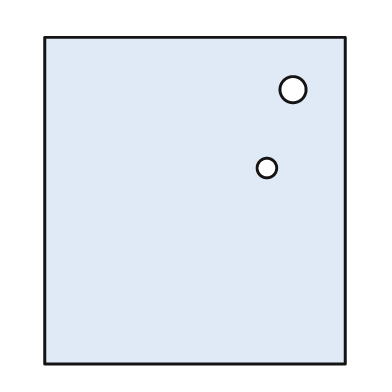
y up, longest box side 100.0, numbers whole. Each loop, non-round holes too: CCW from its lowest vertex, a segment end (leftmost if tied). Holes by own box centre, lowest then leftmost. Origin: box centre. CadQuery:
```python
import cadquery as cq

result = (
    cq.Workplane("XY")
    .moveTo(-46.0, -50.0)
    .lineTo(46.0, -50.0)
    .lineTo(46.0, 50.0)
    .lineTo(-46.0, 50.0)
    .close()
    .moveTo(22.0, 10.0)
    .circle(3.0)
    .moveTo(30.0, 34.0)
    .circle(4.0)
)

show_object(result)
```